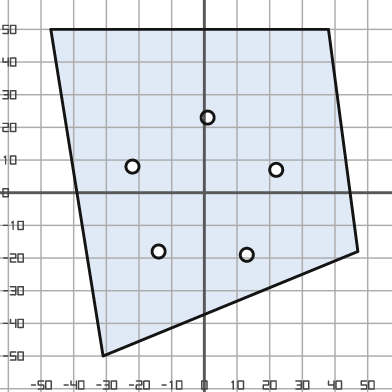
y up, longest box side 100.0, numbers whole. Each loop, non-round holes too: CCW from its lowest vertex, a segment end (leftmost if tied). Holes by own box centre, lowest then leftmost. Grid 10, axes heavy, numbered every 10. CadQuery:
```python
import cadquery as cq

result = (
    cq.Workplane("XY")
    .moveTo(-31.0, -50.0)
    .lineTo(47.0, -18.0)
    .lineTo(38.0, 50.0)
    .lineTo(-47.0, 50.0)
    .close()
    .moveTo(13.0, -19.0)
    .circle(2.0)
    .moveTo(-14.0, -18.0)
    .circle(2.0)
    .moveTo(22.0, 7.0)
    .circle(2.0)
    .moveTo(-22.0, 8.0)
    .circle(2.0)
    .moveTo(1.0, 23.0)
    .circle(2.0)
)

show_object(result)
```